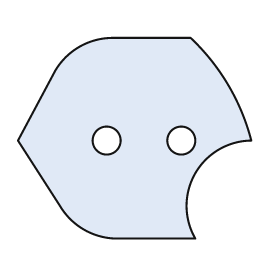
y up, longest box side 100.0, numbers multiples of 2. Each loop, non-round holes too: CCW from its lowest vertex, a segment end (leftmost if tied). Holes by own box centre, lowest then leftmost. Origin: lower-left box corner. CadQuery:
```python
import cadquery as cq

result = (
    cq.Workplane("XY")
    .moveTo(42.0, 0.0)
    .lineTo(76.0, 0.0)
    .threePointArc((76.0, 28.0), (100.0, 42.0))
    .threePointArc((90.0, 66.0), (74.0, 86.0))
    .lineTo(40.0, 86.0)
    .threePointArc((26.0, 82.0), (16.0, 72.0))
    .lineTo(0.0, 42.0)
    .lineTo(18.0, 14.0)
    .threePointArc((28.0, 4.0), (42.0, 0.0))
    .close()
    .moveTo(38.0, 42.0)
    .circle(6.0)
    .moveTo(70.0, 42.0)
    .circle(6.0)
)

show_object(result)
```